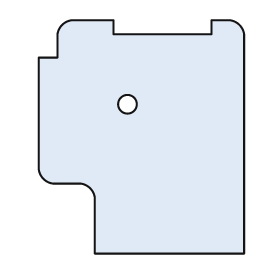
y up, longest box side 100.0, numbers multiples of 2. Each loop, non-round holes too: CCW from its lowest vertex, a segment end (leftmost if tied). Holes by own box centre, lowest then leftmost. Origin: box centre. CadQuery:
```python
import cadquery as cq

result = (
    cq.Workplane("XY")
    .moveTo(-20.0, -50.0)
    .lineTo(44.0, -50.0)
    .lineTo(44.0, 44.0)
    .threePointArc((42.0, 48.0), (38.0, 50.0))
    .lineTo(30.0, 50.0)
    .lineTo(30.0, 44.0)
    .lineTo(-12.0, 44.0)
    .lineTo(-12.0, 50.0)
    .lineTo(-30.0, 50.0)
    .threePointArc((-34.0, 48.0), (-36.0, 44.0))
    .lineTo(-36.0, 34.0)
    .lineTo(-44.0, 34.0)
    .lineTo(-44.0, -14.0)
    .threePointArc((-42.0, -18.0), (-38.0, -20.0))
    .lineTo(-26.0, -20.0)
    .threePointArc((-22.0, -22.0), (-20.0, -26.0))
    .close()
    .moveTo(-6.0, 14.0)
    .circle(4.0)
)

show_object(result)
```